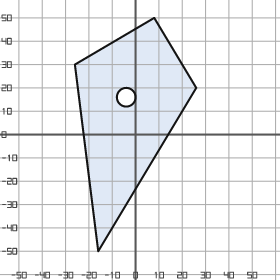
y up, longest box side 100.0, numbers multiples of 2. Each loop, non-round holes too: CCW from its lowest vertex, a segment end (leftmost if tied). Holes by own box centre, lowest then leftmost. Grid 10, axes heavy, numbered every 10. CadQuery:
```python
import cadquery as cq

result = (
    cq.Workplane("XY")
    .moveTo(-16.0, -50.0)
    .lineTo(26.0, 20.0)
    .lineTo(8.0, 50.0)
    .lineTo(-26.0, 30.0)
    .close()
    .moveTo(-4.0, 16.0)
    .circle(4.0)
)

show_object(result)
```